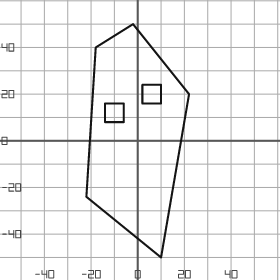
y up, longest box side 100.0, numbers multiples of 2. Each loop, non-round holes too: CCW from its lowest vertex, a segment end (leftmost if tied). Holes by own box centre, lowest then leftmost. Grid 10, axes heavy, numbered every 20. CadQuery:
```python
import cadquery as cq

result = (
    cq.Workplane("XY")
    .moveTo(10.0, -50.0)
    .lineTo(22.0, 20.0)
    .lineTo(-2.0, 50.0)
    .lineTo(-18.0, 40.0)
    .lineTo(-22.0, -24.0)
    .close()
    .moveTo(-14.0, 8.0)
    .lineTo(-6.0, 8.0)
    .lineTo(-6.0, 16.0)
    .lineTo(-14.0, 16.0)
    .close()
    .moveTo(2.0, 16.0)
    .lineTo(10.0, 16.0)
    .lineTo(10.0, 24.0)
    .lineTo(2.0, 24.0)
    .close()
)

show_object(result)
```